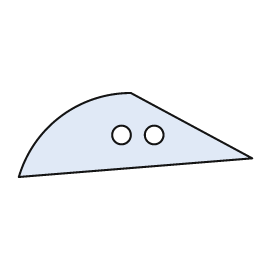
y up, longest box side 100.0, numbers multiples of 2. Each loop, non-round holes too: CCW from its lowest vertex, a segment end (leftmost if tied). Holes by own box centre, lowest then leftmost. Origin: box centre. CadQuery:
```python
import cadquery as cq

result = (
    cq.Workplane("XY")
    .moveTo(-50.0, -18.0)
    .lineTo(50.0, -10.0)
    .lineTo(-2.0, 18.0)
    .threePointArc((-32.0, 8.0), (-50.0, -18.0))
    .close()
    .moveTo(-6.0, 0.0)
    .circle(4.0)
    .moveTo(8.0, 0.0)
    .circle(4.0)
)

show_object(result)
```